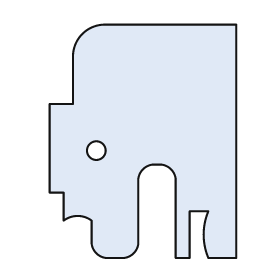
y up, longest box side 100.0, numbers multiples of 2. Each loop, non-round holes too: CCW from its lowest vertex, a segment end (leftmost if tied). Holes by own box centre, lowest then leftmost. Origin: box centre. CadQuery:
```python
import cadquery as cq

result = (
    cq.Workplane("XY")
    .moveTo(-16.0, -50.0)
    .lineTo(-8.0, -50.0)
    .threePointArc((-4.0, -48.0), (-2.0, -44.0))
    .lineTo(-2.0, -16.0)
    .threePointArc((0.0, -12.0), (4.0, -10.0))
    .lineTo(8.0, -10.0)
    .threePointArc((12.0, -12.0), (14.0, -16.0))
    .lineTo(14.0, -50.0)
    .lineTo(20.0, -50.0)
    .lineTo(20.0, -30.0)
    .lineTo(28.0, -30.0)
    .threePointArc((26.0, -40.0), (28.0, -50.0))
    .lineTo(40.0, -50.0)
    .lineTo(40.0, 50.0)
    .lineTo(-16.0, 50.0)
    .threePointArc((-26.0, 46.0), (-30.0, 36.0))
    .lineTo(-30.0, 16.0)
    .lineTo(-40.0, 16.0)
    .lineTo(-40.0, -22.0)
    .lineTo(-34.0, -22.0)
    .lineTo(-34.0, -34.0)
    .threePointArc((-28.0, -32.0), (-22.0, -34.0))
    .lineTo(-22.0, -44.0)
    .threePointArc((-20.0, -48.0), (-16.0, -50.0))
    .close()
    .moveTo(-20.0, -4.0)
    .circle(4.0)
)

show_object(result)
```